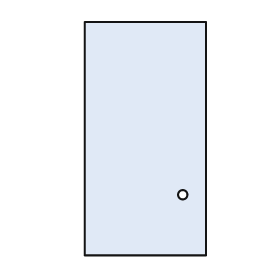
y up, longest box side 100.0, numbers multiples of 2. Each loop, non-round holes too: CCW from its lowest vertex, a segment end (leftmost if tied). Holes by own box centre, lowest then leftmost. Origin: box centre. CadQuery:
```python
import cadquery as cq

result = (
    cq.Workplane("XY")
    .moveTo(-26.0, -50.0)
    .lineTo(26.0, -50.0)
    .lineTo(26.0, 50.0)
    .lineTo(-26.0, 50.0)
    .close()
    .moveTo(16.0, -24.0)
    .circle(2.0)
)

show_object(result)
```